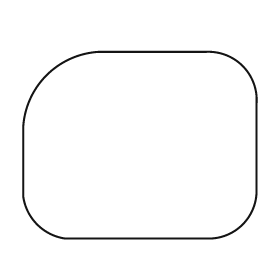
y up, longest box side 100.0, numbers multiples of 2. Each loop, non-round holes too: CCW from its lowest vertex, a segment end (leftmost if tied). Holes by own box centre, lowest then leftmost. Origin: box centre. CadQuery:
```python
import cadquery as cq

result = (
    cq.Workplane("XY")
    .moveTo(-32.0, -40.0)
    .lineTo(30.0, -40.0)
    .threePointArc((44.0, -34.0), (50.0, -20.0))
    .lineTo(50.0, 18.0)
    .threePointArc((44.0, 34.0), (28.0, 40.0))
    .lineTo(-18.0, 40.0)
    .threePointArc((-40.0, 30.0), (-50.0, 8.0))
    .lineTo(-50.0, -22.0)
    .threePointArc((-44.0, -34.0), (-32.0, -40.0))
    .close()
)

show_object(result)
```